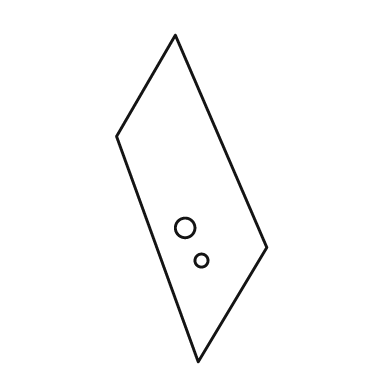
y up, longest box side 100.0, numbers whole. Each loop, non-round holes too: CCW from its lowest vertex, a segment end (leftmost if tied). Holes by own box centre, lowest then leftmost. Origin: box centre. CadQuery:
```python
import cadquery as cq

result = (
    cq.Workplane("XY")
    .moveTo(2.0, -50.0)
    .lineTo(23.0, -15.0)
    .lineTo(-5.0, 50.0)
    .lineTo(-23.0, 19.0)
    .close()
    .moveTo(3.0, -19.0)
    .circle(2.0)
    .moveTo(-2.0, -9.0)
    .circle(3.0)
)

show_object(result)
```